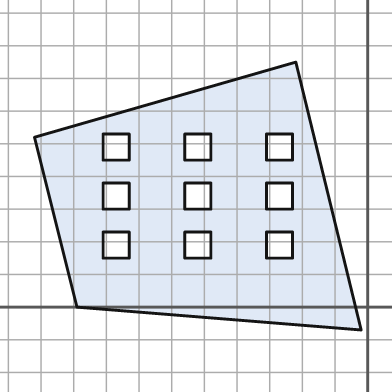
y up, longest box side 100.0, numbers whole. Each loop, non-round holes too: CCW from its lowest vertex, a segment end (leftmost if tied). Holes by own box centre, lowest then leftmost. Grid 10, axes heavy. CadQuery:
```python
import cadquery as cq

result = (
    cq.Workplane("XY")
    .moveTo(-2.0, -7.0)
    .lineTo(-22.0, 75.0)
    .lineTo(-102.0, 52.0)
    .lineTo(-89.0, 0.0)
    .close()
    .moveTo(-81.0, 15.0)
    .lineTo(-73.0, 15.0)
    .lineTo(-73.0, 23.0)
    .lineTo(-81.0, 23.0)
    .close()
    .moveTo(-56.0, 15.0)
    .lineTo(-48.0, 15.0)
    .lineTo(-48.0, 23.0)
    .lineTo(-56.0, 23.0)
    .close()
    .moveTo(-31.0, 15.0)
    .lineTo(-23.0, 15.0)
    .lineTo(-23.0, 23.0)
    .lineTo(-31.0, 23.0)
    .close()
    .moveTo(-81.0, 30.0)
    .lineTo(-73.0, 30.0)
    .lineTo(-73.0, 38.0)
    .lineTo(-81.0, 38.0)
    .close()
    .moveTo(-56.0, 30.0)
    .lineTo(-48.0, 30.0)
    .lineTo(-48.0, 38.0)
    .lineTo(-56.0, 38.0)
    .close()
    .moveTo(-31.0, 30.0)
    .lineTo(-23.0, 30.0)
    .lineTo(-23.0, 38.0)
    .lineTo(-31.0, 38.0)
    .close()
    .moveTo(-81.0, 45.0)
    .lineTo(-73.0, 45.0)
    .lineTo(-73.0, 53.0)
    .lineTo(-81.0, 53.0)
    .close()
    .moveTo(-56.0, 45.0)
    .lineTo(-48.0, 45.0)
    .lineTo(-48.0, 53.0)
    .lineTo(-56.0, 53.0)
    .close()
    .moveTo(-31.0, 45.0)
    .lineTo(-23.0, 45.0)
    .lineTo(-23.0, 53.0)
    .lineTo(-31.0, 53.0)
    .close()
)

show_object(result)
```